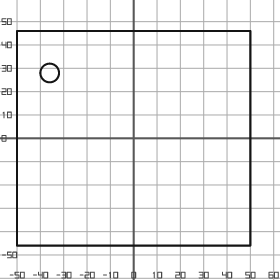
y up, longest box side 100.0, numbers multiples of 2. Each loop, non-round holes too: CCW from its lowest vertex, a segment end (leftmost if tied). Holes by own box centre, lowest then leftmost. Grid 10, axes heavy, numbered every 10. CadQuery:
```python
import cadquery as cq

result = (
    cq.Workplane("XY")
    .moveTo(-50.0, -46.0)
    .lineTo(50.0, -46.0)
    .lineTo(50.0, 46.0)
    .lineTo(-50.0, 46.0)
    .close()
    .moveTo(-36.0, 28.0)
    .circle(4.0)
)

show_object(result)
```